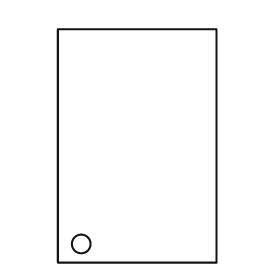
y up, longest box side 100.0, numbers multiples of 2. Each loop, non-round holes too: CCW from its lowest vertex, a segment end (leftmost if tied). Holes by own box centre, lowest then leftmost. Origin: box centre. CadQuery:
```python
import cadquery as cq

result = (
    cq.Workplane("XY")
    .moveTo(-34.0, -50.0)
    .lineTo(34.0, -50.0)
    .lineTo(34.0, 50.0)
    .lineTo(-34.0, 50.0)
    .close()
    .moveTo(-24.0, -42.0)
    .circle(4.0)
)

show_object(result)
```